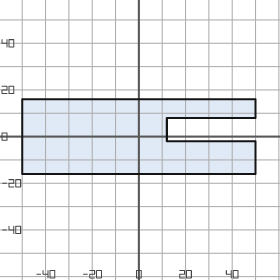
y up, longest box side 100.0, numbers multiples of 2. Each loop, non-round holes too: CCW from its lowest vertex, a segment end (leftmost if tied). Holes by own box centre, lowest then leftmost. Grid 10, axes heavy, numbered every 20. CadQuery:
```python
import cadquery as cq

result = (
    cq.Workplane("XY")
    .moveTo(-50.0, -16.0)
    .lineTo(50.0, -16.0)
    .lineTo(50.0, -2.0)
    .lineTo(12.0, -2.0)
    .lineTo(12.0, 8.0)
    .lineTo(50.0, 8.0)
    .lineTo(50.0, 16.0)
    .lineTo(-50.0, 16.0)
    .close()
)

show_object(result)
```